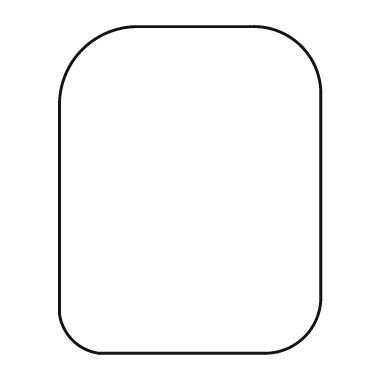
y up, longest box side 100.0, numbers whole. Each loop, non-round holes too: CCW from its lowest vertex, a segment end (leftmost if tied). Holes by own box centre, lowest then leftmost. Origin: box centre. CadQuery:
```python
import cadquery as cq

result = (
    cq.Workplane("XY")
    .moveTo(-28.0, -50.0)
    .lineTo(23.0, -50.0)
    .threePointArc((35.0, -45.0), (40.0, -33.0))
    .lineTo(40.0, 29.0)
    .threePointArc((34.0, 44.0), (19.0, 50.0))
    .lineTo(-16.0, 50.0)
    .threePointArc((-33.0, 43.0), (-40.0, 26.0))
    .lineTo(-40.0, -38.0)
    .threePointArc((-36.0, -46.0), (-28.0, -50.0))
    .close()
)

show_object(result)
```